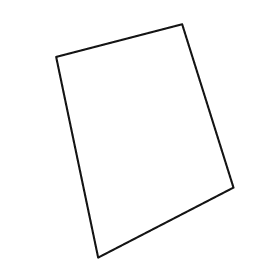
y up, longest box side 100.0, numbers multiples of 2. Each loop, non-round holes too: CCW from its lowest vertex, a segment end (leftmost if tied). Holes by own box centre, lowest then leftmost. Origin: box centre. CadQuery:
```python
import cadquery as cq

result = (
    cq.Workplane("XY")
    .moveTo(-20.0, -50.0)
    .lineTo(38.0, -20.0)
    .lineTo(16.0, 50.0)
    .lineTo(-38.0, 36.0)
    .close()
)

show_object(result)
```